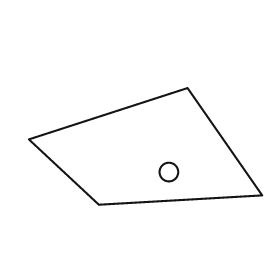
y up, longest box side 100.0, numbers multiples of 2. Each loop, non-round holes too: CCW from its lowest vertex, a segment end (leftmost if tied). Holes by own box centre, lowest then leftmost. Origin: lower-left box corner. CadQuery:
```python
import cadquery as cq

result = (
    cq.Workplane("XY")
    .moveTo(30.0, 0.0)
    .lineTo(100.0, 4.0)
    .lineTo(68.0, 50.0)
    .lineTo(0.0, 28.0)
    .close()
    .moveTo(60.0, 14.0)
    .circle(4.0)
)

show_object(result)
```